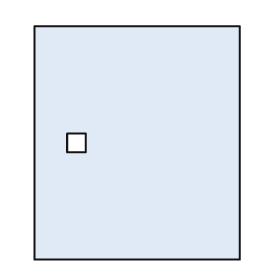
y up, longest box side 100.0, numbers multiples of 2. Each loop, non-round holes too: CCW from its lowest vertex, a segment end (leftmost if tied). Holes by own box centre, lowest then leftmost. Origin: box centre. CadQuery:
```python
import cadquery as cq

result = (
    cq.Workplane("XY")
    .moveTo(-44.0, -50.0)
    .lineTo(44.0, -50.0)
    .lineTo(44.0, 50.0)
    .lineTo(-44.0, 50.0)
    .close()
    .moveTo(-30.0, -4.0)
    .lineTo(-22.0, -4.0)
    .lineTo(-22.0, 4.0)
    .lineTo(-30.0, 4.0)
    .close()
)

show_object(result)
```